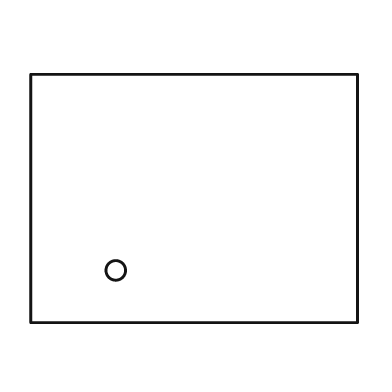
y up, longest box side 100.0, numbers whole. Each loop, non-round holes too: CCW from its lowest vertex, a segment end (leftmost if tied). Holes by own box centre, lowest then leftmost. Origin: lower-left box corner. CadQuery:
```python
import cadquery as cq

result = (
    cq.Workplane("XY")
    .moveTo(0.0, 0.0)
    .lineTo(100.0, 0.0)
    .lineTo(100.0, 76.0)
    .lineTo(0.0, 76.0)
    .close()
    .moveTo(26.0, 16.0)
    .circle(3.0)
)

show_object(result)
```